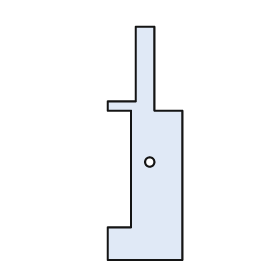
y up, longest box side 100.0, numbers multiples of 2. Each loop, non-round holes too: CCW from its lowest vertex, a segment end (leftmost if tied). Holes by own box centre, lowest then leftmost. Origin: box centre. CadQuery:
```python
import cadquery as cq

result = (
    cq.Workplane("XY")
    .moveTo(-16.0, -50.0)
    .lineTo(16.0, -50.0)
    .lineTo(16.0, 14.0)
    .lineTo(4.0, 14.0)
    .lineTo(4.0, 50.0)
    .lineTo(-4.0, 50.0)
    .lineTo(-4.0, 18.0)
    .lineTo(-16.0, 18.0)
    .lineTo(-16.0, 14.0)
    .lineTo(-6.0, 14.0)
    .lineTo(-6.0, -36.0)
    .lineTo(-16.0, -36.0)
    .close()
    .moveTo(2.0, -8.0)
    .circle(2.0)
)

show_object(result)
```